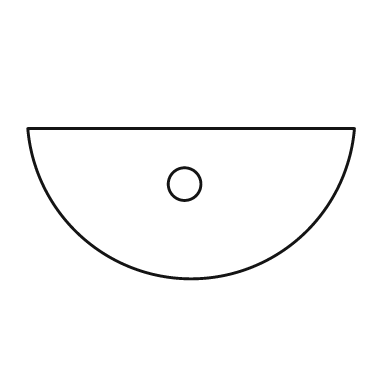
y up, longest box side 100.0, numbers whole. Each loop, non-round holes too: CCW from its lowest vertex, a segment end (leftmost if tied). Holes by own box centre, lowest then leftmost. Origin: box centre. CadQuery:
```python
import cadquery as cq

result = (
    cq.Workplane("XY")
    .moveTo(-50.0, 23.0)
    .threePointArc((0.0, -23.0), (50.0, 23.0))
    .close()
    .moveTo(-2.0, 6.0)
    .circle(5.0)
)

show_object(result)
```